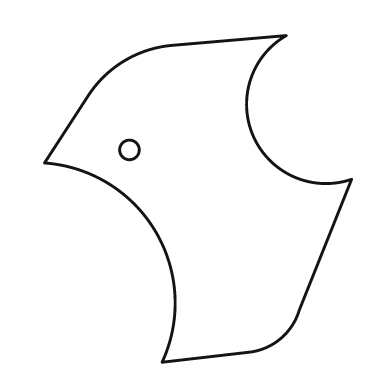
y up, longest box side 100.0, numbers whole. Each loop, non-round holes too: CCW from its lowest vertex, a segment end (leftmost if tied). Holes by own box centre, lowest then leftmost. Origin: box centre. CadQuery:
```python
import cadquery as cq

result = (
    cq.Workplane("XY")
    .moveTo(-11.0, -50.0)
    .lineTo(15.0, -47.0)
    .threePointArc((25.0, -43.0), (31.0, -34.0))
    .lineTo(47.0, 6.0)
    .threePointArc((17.0, 19.0), (27.0, 50.0))
    .lineTo(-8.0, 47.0)
    .threePointArc((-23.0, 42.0), (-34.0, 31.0))
    .lineTo(-47.0, 11.0)
    .threePointArc((-13.0, -10.0), (-11.0, -50.0))
    .close()
    .moveTo(-21.0, 15.0)
    .circle(3.0)
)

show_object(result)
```